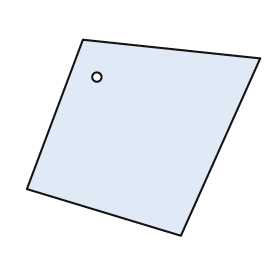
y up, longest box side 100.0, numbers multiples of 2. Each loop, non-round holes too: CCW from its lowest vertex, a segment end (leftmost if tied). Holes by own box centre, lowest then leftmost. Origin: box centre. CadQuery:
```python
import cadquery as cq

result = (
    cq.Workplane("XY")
    .moveTo(16.0, -42.0)
    .lineTo(50.0, 34.0)
    .lineTo(-26.0, 42.0)
    .lineTo(-50.0, -22.0)
    .close()
    .moveTo(-20.0, 26.0)
    .circle(2.0)
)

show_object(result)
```